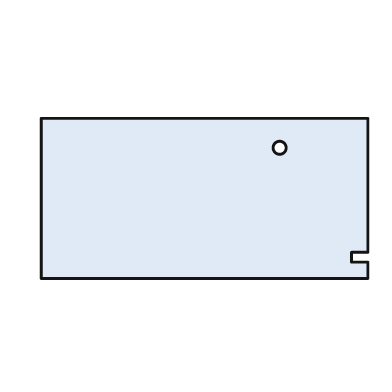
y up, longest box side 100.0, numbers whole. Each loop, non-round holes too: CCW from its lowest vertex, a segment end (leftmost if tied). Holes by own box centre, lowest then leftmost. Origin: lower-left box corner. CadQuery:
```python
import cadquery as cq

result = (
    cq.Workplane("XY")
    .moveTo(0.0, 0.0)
    .lineTo(100.0, 0.0)
    .lineTo(100.0, 5.0)
    .lineTo(95.0, 5.0)
    .lineTo(95.0, 8.0)
    .lineTo(100.0, 8.0)
    .lineTo(100.0, 49.0)
    .lineTo(0.0, 49.0)
    .close()
    .moveTo(73.0, 40.0)
    .circle(2.0)
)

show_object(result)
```